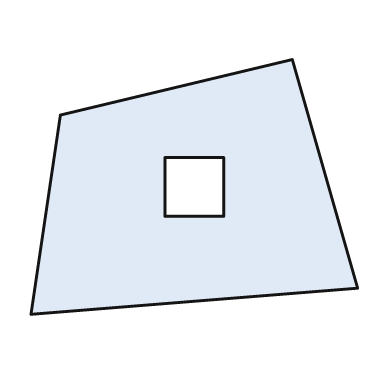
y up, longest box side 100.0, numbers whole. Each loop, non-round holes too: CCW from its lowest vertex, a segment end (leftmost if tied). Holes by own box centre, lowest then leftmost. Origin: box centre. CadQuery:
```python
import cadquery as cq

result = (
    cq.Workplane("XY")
    .moveTo(-50.0, -39.0)
    .lineTo(50.0, -31.0)
    .lineTo(30.0, 39.0)
    .lineTo(-41.0, 22.0)
    .close()
    .moveTo(-9.0, -9.0)
    .lineTo(9.0, -9.0)
    .lineTo(9.0, 9.0)
    .lineTo(-9.0, 9.0)
    .close()
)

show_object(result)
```